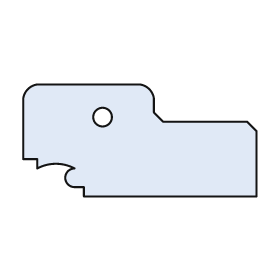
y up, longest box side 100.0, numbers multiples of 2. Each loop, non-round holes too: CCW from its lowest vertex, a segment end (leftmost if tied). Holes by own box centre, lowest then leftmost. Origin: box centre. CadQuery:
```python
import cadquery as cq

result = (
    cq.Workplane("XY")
    .moveTo(-24.0, -24.0)
    .lineTo(50.0, -24.0)
    .lineTo(50.0, 4.0)
    .lineTo(46.0, 8.0)
    .lineTo(10.0, 8.0)
    .lineTo(6.0, 12.0)
    .lineTo(6.0, 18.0)
    .threePointArc((4.0, 22.0), (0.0, 24.0))
    .lineTo(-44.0, 24.0)
    .threePointArc((-48.0, 22.0), (-50.0, 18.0))
    .lineTo(-50.0, -8.0)
    .lineTo(-44.0, -8.0)
    .lineTo(-44.0, -12.0)
    .threePointArc((-36.0, -10.0), (-28.0, -12.0))
    .threePointArc((-32.0, -16.0), (-28.0, -20.0))
    .lineTo(-24.0, -20.0)
    .close()
    .moveTo(-16.0, 10.0)
    .circle(4.0)
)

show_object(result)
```